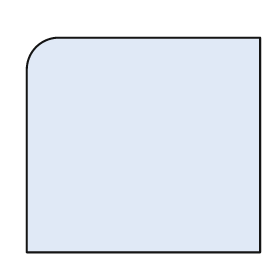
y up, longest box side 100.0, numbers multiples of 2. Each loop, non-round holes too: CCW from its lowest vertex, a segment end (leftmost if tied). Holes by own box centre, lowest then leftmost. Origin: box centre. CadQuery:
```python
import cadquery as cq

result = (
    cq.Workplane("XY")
    .moveTo(-50.0, -46.0)
    .lineTo(50.0, -46.0)
    .lineTo(50.0, 46.0)
    .lineTo(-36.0, 46.0)
    .threePointArc((-46.0, 42.0), (-50.0, 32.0))
    .close()
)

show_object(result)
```